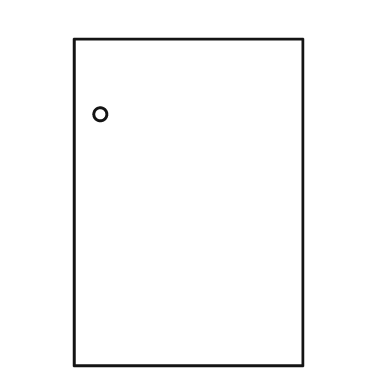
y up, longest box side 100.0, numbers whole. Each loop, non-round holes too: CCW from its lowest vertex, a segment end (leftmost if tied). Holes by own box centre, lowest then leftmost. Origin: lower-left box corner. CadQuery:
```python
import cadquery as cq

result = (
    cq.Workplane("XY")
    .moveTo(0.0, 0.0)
    .lineTo(70.0, 0.0)
    .lineTo(70.0, 100.0)
    .lineTo(0.0, 100.0)
    .close()
    .moveTo(8.0, 77.0)
    .circle(2.0)
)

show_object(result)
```